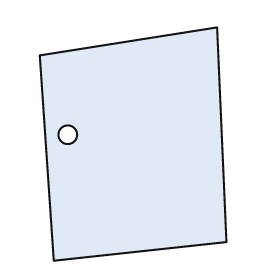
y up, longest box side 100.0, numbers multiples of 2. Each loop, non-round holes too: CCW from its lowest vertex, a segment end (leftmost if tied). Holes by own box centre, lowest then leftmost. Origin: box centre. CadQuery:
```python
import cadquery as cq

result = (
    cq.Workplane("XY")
    .moveTo(-34.0, -50.0)
    .lineTo(40.0, -42.0)
    .lineTo(36.0, 50.0)
    .lineTo(-40.0, 38.0)
    .close()
    .moveTo(-28.0, 4.0)
    .circle(4.0)
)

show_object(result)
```